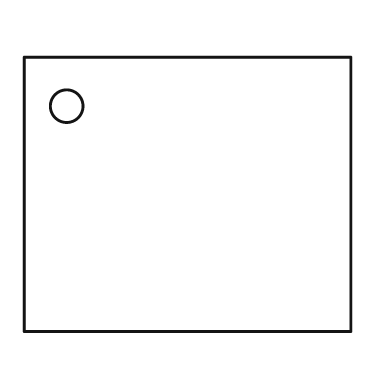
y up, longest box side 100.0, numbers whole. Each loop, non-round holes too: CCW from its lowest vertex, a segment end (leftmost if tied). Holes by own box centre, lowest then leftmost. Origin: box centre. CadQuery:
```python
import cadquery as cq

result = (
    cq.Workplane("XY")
    .moveTo(-50.0, -42.0)
    .lineTo(50.0, -42.0)
    .lineTo(50.0, 42.0)
    .lineTo(-50.0, 42.0)
    .close()
    .moveTo(-37.0, 27.0)
    .circle(5.0)
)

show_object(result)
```